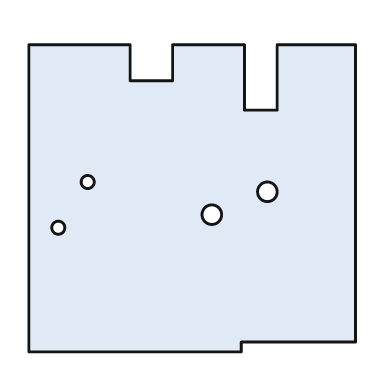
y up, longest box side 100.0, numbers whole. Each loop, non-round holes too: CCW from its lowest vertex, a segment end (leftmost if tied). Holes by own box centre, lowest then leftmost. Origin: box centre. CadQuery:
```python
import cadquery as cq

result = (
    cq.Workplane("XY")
    .moveTo(-50.0, -47.0)
    .lineTo(15.0, -47.0)
    .lineTo(15.0, -44.0)
    .lineTo(50.0, -44.0)
    .lineTo(50.0, 47.0)
    .lineTo(26.0, 47.0)
    .lineTo(26.0, 27.0)
    .lineTo(16.0, 27.0)
    .lineTo(16.0, 47.0)
    .lineTo(-6.0, 47.0)
    .lineTo(-6.0, 36.0)
    .lineTo(-19.0, 36.0)
    .lineTo(-19.0, 47.0)
    .lineTo(-50.0, 47.0)
    .close()
    .moveTo(-41.0, -9.0)
    .circle(2.0)
    .moveTo(6.0, -5.0)
    .circle(3.0)
    .moveTo(23.0, 2.0)
    .circle(3.0)
    .moveTo(-32.0, 5.0)
    .circle(2.0)
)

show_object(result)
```